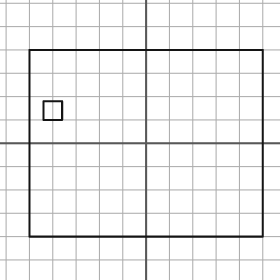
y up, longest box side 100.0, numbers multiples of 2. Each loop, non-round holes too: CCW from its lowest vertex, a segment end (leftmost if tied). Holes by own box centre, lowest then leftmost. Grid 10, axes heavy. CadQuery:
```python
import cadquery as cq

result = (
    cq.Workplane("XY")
    .moveTo(-50.0, -40.0)
    .lineTo(50.0, -40.0)
    .lineTo(50.0, 40.0)
    .lineTo(-50.0, 40.0)
    .close()
    .moveTo(-44.0, 10.0)
    .lineTo(-36.0, 10.0)
    .lineTo(-36.0, 18.0)
    .lineTo(-44.0, 18.0)
    .close()
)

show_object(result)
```